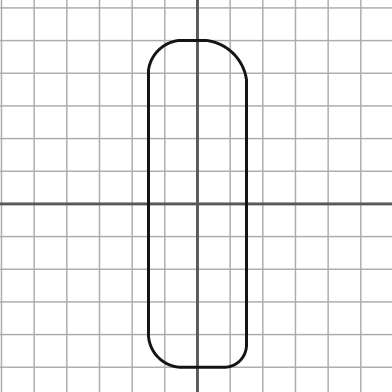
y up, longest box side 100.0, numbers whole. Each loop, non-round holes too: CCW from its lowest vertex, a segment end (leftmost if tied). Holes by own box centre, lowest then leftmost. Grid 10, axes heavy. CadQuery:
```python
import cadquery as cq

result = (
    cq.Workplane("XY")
    .moveTo(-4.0, -50.0)
    .lineTo(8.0, -50.0)
    .threePointArc((13.0, -48.0), (15.0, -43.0))
    .lineTo(15.0, 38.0)
    .threePointArc((11.0, 46.0), (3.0, 50.0))
    .lineTo(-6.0, 50.0)
    .threePointArc((-12.0, 47.0), (-15.0, 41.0))
    .lineTo(-15.0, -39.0)
    .threePointArc((-12.0, -47.0), (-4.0, -50.0))
    .close()
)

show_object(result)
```